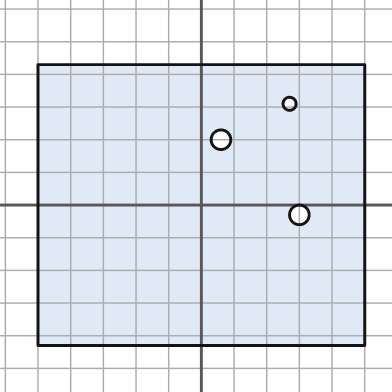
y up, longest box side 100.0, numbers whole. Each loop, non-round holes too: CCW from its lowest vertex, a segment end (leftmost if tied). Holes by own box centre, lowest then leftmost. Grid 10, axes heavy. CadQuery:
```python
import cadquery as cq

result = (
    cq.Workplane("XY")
    .moveTo(-50.0, -43.0)
    .lineTo(50.0, -43.0)
    .lineTo(50.0, 43.0)
    .lineTo(-50.0, 43.0)
    .close()
    .moveTo(30.0, -3.0)
    .circle(3.0)
    .moveTo(6.0, 20.0)
    .circle(3.0)
    .moveTo(27.0, 31.0)
    .circle(2.0)
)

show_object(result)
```